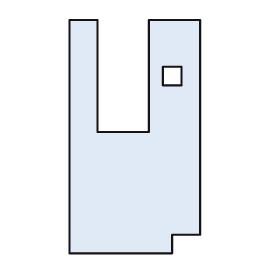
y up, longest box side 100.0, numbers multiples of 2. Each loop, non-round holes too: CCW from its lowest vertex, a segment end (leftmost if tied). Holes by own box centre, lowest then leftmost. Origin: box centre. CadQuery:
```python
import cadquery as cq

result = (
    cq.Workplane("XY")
    .moveTo(-28.0, -50.0)
    .lineTo(16.0, -50.0)
    .lineTo(16.0, -42.0)
    .lineTo(28.0, -42.0)
    .lineTo(28.0, 50.0)
    .lineTo(6.0, 50.0)
    .lineTo(6.0, 2.0)
    .lineTo(-16.0, 2.0)
    .lineTo(-16.0, 50.0)
    .lineTo(-28.0, 50.0)
    .close()
    .moveTo(12.0, 22.0)
    .lineTo(20.0, 22.0)
    .lineTo(20.0, 30.0)
    .lineTo(12.0, 30.0)
    .close()
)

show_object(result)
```